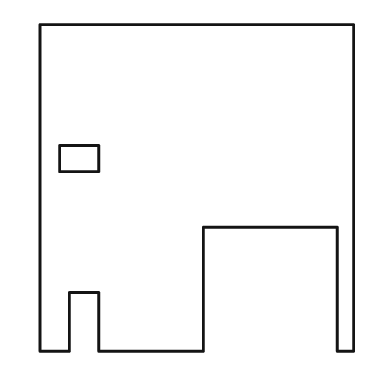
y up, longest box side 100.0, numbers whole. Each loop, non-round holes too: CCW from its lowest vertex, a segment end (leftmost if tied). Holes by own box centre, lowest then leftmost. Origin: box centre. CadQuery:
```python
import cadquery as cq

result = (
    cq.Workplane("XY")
    .moveTo(-48.0, -50.0)
    .lineTo(-39.0, -50.0)
    .lineTo(-39.0, -32.0)
    .lineTo(-30.0, -32.0)
    .lineTo(-30.0, -50.0)
    .lineTo(2.0, -50.0)
    .lineTo(2.0, -12.0)
    .lineTo(43.0, -12.0)
    .lineTo(43.0, -50.0)
    .lineTo(48.0, -50.0)
    .lineTo(48.0, 50.0)
    .lineTo(-48.0, 50.0)
    .close()
    .moveTo(-42.0, 5.0)
    .lineTo(-30.0, 5.0)
    .lineTo(-30.0, 13.0)
    .lineTo(-42.0, 13.0)
    .close()
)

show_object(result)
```